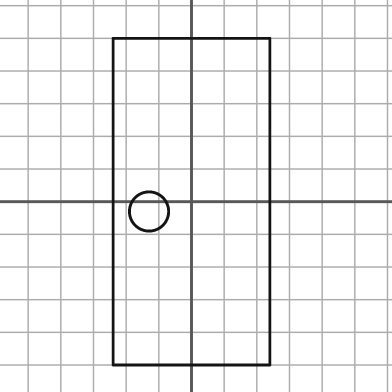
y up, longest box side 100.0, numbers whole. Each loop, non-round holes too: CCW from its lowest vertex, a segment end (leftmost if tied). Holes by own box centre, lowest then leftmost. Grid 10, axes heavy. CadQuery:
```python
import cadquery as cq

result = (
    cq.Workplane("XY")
    .moveTo(-24.0, -50.0)
    .lineTo(24.0, -50.0)
    .lineTo(24.0, 50.0)
    .lineTo(-24.0, 50.0)
    .close()
    .moveTo(-13.0, -3.0)
    .circle(6.0)
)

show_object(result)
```